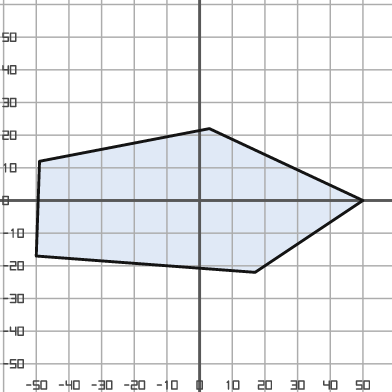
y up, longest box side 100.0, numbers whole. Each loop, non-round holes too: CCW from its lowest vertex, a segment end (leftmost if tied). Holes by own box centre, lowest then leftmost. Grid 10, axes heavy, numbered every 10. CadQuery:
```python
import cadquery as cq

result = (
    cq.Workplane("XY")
    .moveTo(17.0, -22.0)
    .lineTo(50.0, 0.0)
    .lineTo(3.0, 22.0)
    .lineTo(-49.0, 12.0)
    .lineTo(-50.0, -17.0)
    .close()
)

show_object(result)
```